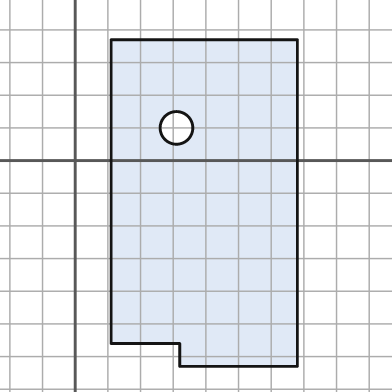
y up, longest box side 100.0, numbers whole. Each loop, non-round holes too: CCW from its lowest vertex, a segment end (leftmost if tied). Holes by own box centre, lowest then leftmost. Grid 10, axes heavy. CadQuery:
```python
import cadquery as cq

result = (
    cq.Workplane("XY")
    .moveTo(32.0, -63.0)
    .lineTo(68.0, -63.0)
    .lineTo(68.0, 37.0)
    .lineTo(11.0, 37.0)
    .lineTo(11.0, -56.0)
    .lineTo(32.0, -56.0)
    .close()
    .moveTo(31.0, 10.0)
    .circle(5.0)
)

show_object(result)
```